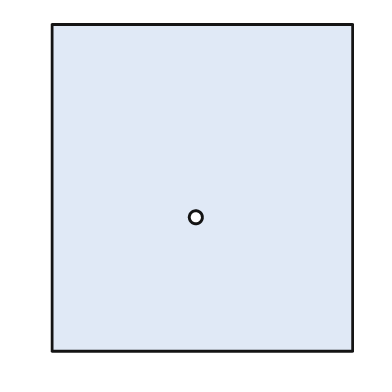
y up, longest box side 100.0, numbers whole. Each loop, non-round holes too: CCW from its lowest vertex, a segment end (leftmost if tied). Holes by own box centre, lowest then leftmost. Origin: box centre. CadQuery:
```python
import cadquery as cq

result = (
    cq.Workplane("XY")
    .moveTo(-46.0, -50.0)
    .lineTo(46.0, -50.0)
    .lineTo(46.0, 50.0)
    .lineTo(-46.0, 50.0)
    .close()
    .moveTo(-2.0, -9.0)
    .circle(2.0)
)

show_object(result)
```